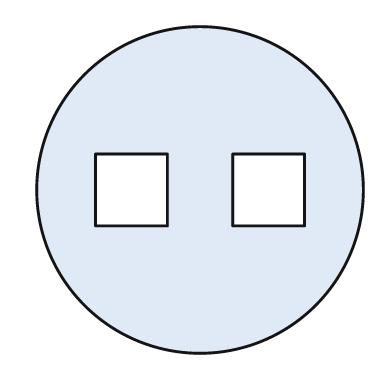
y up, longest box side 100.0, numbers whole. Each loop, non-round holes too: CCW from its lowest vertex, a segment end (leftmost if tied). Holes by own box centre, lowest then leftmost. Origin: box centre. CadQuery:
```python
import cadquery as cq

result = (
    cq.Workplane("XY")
    .moveTo(0.0, 0.0)
    .circle(50.0)
    .moveTo(-32.0, -11.0)
    .lineTo(-10.0, -11.0)
    .lineTo(-10.0, 11.0)
    .lineTo(-32.0, 11.0)
    .close()
    .moveTo(10.0, -11.0)
    .lineTo(32.0, -11.0)
    .lineTo(32.0, 11.0)
    .lineTo(10.0, 11.0)
    .close()
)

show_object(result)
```